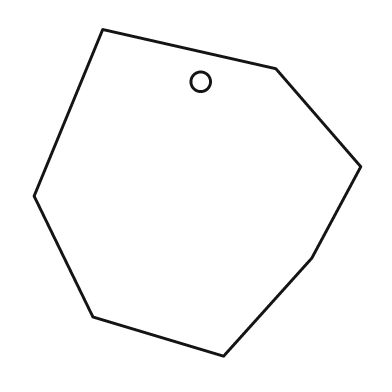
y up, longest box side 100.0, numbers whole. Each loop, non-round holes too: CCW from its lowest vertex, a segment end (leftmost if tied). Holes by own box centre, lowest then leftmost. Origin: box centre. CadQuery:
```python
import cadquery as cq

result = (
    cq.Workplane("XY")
    .moveTo(8.0, -50.0)
    .lineTo(35.0, -20.0)
    .lineTo(50.0, 8.0)
    .lineTo(24.0, 38.0)
    .lineTo(-29.0, 50.0)
    .lineTo(-50.0, -1.0)
    .lineTo(-32.0, -38.0)
    .close()
    .moveTo(1.0, 34.0)
    .circle(3.0)
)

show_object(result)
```